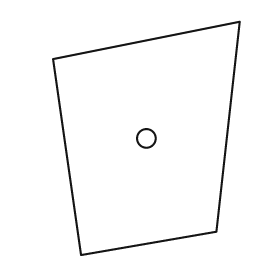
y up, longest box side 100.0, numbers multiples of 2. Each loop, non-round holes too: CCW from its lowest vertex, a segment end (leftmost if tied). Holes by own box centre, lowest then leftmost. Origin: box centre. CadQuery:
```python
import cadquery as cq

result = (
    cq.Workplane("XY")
    .moveTo(-28.0, -50.0)
    .lineTo(30.0, -40.0)
    .lineTo(40.0, 50.0)
    .lineTo(-40.0, 34.0)
    .close()
    .moveTo(0.0, 0.0)
    .circle(4.0)
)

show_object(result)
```